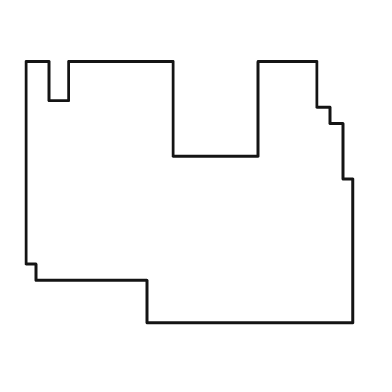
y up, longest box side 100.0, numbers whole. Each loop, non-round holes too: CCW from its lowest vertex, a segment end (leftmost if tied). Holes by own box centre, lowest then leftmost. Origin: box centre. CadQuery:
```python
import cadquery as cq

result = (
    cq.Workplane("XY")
    .moveTo(-13.0, -40.0)
    .lineTo(50.0, -40.0)
    .lineTo(50.0, 4.0)
    .lineTo(47.0, 4.0)
    .lineTo(47.0, 21.0)
    .lineTo(43.0, 21.0)
    .lineTo(43.0, 26.0)
    .lineTo(39.0, 26.0)
    .lineTo(39.0, 40.0)
    .lineTo(21.0, 40.0)
    .lineTo(21.0, 11.0)
    .lineTo(-5.0, 11.0)
    .lineTo(-5.0, 40.0)
    .lineTo(-37.0, 40.0)
    .lineTo(-37.0, 28.0)
    .lineTo(-43.0, 28.0)
    .lineTo(-43.0, 40.0)
    .lineTo(-50.0, 40.0)
    .lineTo(-50.0, -22.0)
    .lineTo(-47.0, -22.0)
    .lineTo(-47.0, -27.0)
    .lineTo(-13.0, -27.0)
    .close()
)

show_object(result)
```